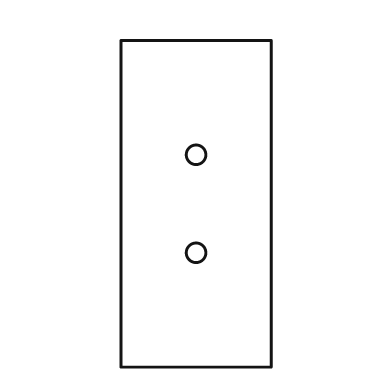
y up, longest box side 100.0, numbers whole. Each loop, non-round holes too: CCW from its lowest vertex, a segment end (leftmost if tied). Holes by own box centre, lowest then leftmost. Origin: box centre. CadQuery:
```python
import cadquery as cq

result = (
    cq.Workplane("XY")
    .moveTo(-23.0, -50.0)
    .lineTo(23.0, -50.0)
    .lineTo(23.0, 50.0)
    .lineTo(-23.0, 50.0)
    .close()
    .moveTo(0.0, -15.0)
    .circle(3.0)
    .moveTo(0.0, 15.0)
    .circle(3.0)
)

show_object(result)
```